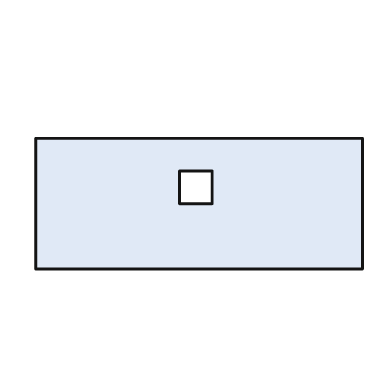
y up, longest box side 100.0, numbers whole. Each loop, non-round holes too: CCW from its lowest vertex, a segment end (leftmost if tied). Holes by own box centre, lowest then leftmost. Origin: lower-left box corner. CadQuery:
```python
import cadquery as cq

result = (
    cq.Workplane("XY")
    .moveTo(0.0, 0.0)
    .lineTo(100.0, 0.0)
    .lineTo(100.0, 40.0)
    .lineTo(0.0, 40.0)
    .close()
    .moveTo(44.0, 20.0)
    .lineTo(54.0, 20.0)
    .lineTo(54.0, 30.0)
    .lineTo(44.0, 30.0)
    .close()
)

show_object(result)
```